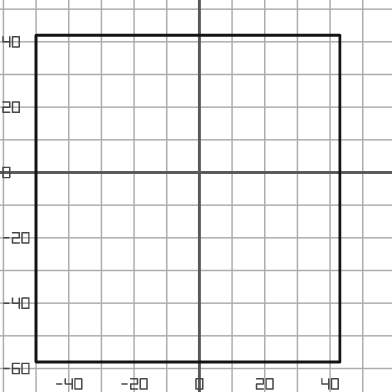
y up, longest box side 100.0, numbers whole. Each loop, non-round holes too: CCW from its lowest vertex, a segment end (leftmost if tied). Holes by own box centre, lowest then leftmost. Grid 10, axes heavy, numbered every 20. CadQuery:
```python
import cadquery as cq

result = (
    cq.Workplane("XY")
    .moveTo(-50.0, -58.0)
    .lineTo(43.0, -58.0)
    .lineTo(43.0, 42.0)
    .lineTo(-50.0, 42.0)
    .close()
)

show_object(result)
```